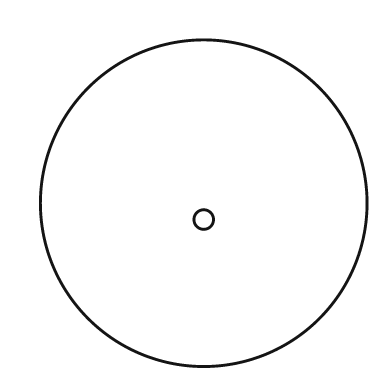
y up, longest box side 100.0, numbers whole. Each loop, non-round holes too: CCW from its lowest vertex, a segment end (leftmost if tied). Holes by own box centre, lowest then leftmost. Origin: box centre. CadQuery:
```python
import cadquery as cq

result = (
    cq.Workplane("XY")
    .moveTo(0.0, 0.0)
    .circle(50.0)
    .moveTo(0.0, -5.0)
    .circle(3.0)
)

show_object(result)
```